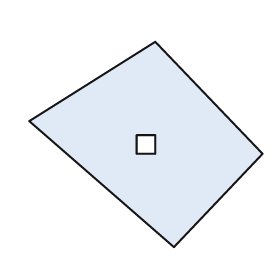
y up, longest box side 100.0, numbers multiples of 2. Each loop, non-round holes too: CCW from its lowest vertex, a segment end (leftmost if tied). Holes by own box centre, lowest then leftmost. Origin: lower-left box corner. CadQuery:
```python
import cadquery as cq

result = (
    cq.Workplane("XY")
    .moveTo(62.0, 0.0)
    .lineTo(100.0, 40.0)
    .lineTo(54.0, 88.0)
    .lineTo(0.0, 54.0)
    .close()
    .moveTo(46.0, 40.0)
    .lineTo(54.0, 40.0)
    .lineTo(54.0, 48.0)
    .lineTo(46.0, 48.0)
    .close()
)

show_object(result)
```